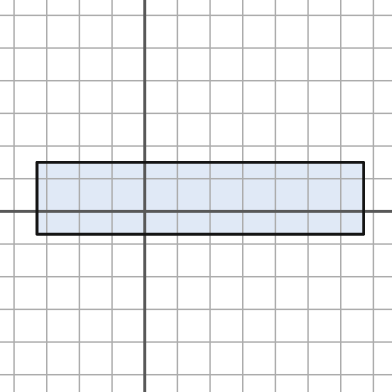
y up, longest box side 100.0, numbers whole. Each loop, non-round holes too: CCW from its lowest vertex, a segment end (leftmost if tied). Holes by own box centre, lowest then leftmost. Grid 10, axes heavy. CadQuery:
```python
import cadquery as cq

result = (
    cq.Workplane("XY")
    .moveTo(-33.0, -7.0)
    .lineTo(67.0, -7.0)
    .lineTo(67.0, 15.0)
    .lineTo(-33.0, 15.0)
    .close()
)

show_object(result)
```